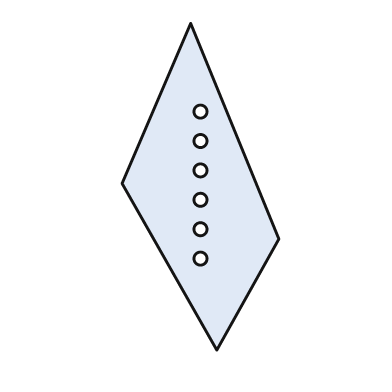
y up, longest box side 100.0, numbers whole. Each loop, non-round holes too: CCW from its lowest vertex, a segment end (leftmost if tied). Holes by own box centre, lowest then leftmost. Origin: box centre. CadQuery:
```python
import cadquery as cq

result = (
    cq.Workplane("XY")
    .moveTo(5.0, -50.0)
    .lineTo(24.0, -16.0)
    .lineTo(-3.0, 50.0)
    .lineTo(-24.0, 1.0)
    .close()
    .moveTo(0.0, -22.0)
    .circle(2.0)
    .moveTo(0.0, -13.0)
    .circle(2.0)
    .moveTo(0.0, -4.0)
    .circle(2.0)
    .moveTo(0.0, 5.0)
    .circle(2.0)
    .moveTo(0.0, 14.0)
    .circle(2.0)
    .moveTo(0.0, 23.0)
    .circle(2.0)
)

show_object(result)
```